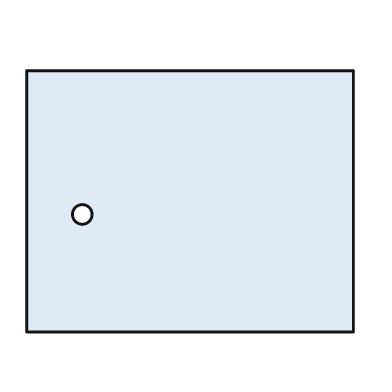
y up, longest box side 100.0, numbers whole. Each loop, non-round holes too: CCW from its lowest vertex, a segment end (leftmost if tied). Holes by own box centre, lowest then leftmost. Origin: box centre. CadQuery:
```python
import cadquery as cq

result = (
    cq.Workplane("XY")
    .moveTo(-50.0, -40.0)
    .lineTo(50.0, -40.0)
    .lineTo(50.0, 40.0)
    .lineTo(-50.0, 40.0)
    .close()
    .moveTo(-33.0, -4.0)
    .circle(3.0)
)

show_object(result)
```